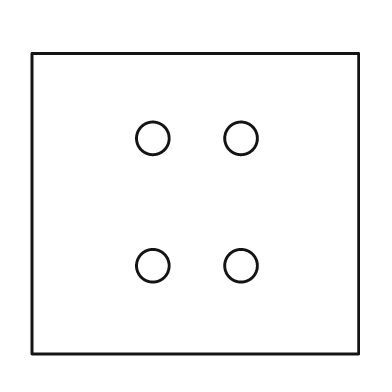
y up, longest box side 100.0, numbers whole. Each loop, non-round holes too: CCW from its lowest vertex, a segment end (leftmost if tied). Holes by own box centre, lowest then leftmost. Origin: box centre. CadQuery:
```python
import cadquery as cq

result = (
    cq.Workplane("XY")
    .moveTo(-50.0, -46.0)
    .lineTo(50.0, -46.0)
    .lineTo(50.0, 46.0)
    .lineTo(-50.0, 46.0)
    .close()
    .moveTo(-13.0, -19.0)
    .circle(5.0)
    .moveTo(14.0, -19.0)
    .circle(5.0)
    .moveTo(-13.0, 20.0)
    .circle(5.0)
    .moveTo(14.0, 20.0)
    .circle(5.0)
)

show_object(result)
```